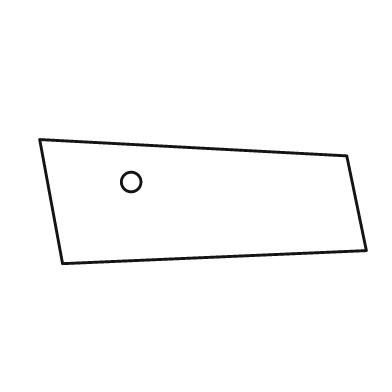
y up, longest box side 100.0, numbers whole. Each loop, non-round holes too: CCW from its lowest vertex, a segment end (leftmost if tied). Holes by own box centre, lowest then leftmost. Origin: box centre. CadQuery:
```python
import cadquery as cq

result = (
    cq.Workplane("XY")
    .moveTo(-43.0, -19.0)
    .lineTo(50.0, -15.0)
    .lineTo(44.0, 14.0)
    .lineTo(-50.0, 19.0)
    .close()
    .moveTo(-22.0, 6.0)
    .circle(3.0)
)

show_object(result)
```